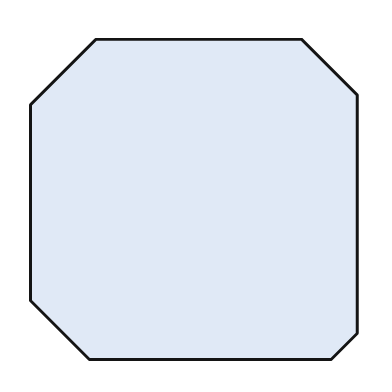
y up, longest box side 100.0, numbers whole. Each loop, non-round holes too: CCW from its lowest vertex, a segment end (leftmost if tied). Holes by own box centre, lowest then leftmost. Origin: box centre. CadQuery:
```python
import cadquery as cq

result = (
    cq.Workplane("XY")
    .moveTo(-32.0, -49.0)
    .lineTo(42.0, -49.0)
    .lineTo(50.0, -41.0)
    .lineTo(50.0, 32.0)
    .lineTo(33.0, 49.0)
    .lineTo(-30.0, 49.0)
    .lineTo(-50.0, 29.0)
    .lineTo(-50.0, -31.0)
    .close()
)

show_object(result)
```